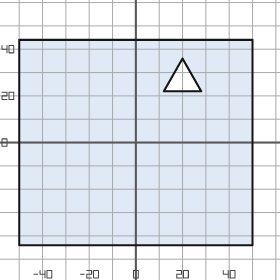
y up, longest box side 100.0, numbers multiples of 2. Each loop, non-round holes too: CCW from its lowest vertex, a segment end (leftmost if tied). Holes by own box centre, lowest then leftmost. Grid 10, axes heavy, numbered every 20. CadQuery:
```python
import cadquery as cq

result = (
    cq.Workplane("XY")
    .moveTo(-50.0, -44.0)
    .lineTo(50.0, -44.0)
    .lineTo(50.0, 44.0)
    .lineTo(-50.0, 44.0)
    .close()
    .moveTo(12.0, 22.0)
    .lineTo(28.0, 22.0)
    .lineTo(20.0, 36.0)
    .close()
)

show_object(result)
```